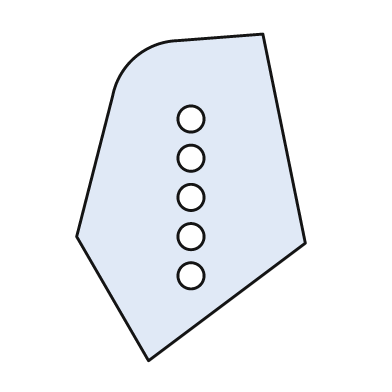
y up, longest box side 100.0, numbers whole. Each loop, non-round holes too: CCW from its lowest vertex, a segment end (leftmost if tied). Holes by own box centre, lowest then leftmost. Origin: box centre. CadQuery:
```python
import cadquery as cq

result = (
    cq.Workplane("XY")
    .moveTo(-13.0, -50.0)
    .lineTo(35.0, -14.0)
    .lineTo(22.0, 50.0)
    .lineTo(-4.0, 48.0)
    .threePointArc((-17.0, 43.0), (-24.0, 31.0))
    .lineTo(-35.0, -12.0)
    .close()
    .moveTo(0.0, -24.0)
    .circle(4.0)
    .moveTo(0.0, -12.0)
    .circle(4.0)
    .moveTo(0.0, 0.0)
    .circle(4.0)
    .moveTo(0.0, 12.0)
    .circle(4.0)
    .moveTo(0.0, 24.0)
    .circle(4.0)
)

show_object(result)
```